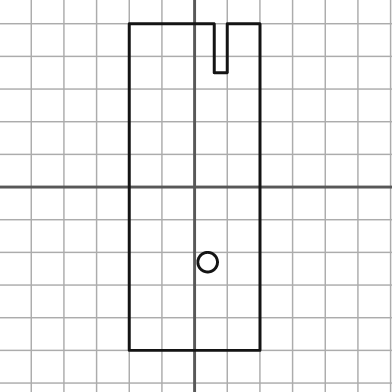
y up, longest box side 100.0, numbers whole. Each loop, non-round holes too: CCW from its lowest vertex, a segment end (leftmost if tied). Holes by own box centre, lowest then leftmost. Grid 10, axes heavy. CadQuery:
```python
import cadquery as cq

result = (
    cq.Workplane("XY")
    .moveTo(-20.0, -50.0)
    .lineTo(20.0, -50.0)
    .lineTo(20.0, 50.0)
    .lineTo(10.0, 50.0)
    .lineTo(10.0, 35.0)
    .lineTo(6.0, 35.0)
    .lineTo(6.0, 50.0)
    .lineTo(-20.0, 50.0)
    .close()
    .moveTo(4.0, -23.0)
    .circle(3.0)
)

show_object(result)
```